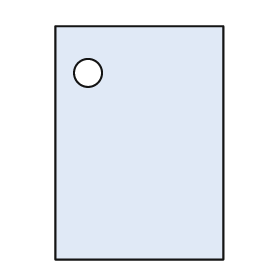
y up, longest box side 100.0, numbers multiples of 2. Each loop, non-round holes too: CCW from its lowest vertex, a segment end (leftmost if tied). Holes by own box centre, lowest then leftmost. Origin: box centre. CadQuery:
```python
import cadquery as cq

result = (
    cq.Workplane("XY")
    .moveTo(-36.0, -50.0)
    .lineTo(36.0, -50.0)
    .lineTo(36.0, 50.0)
    .lineTo(-36.0, 50.0)
    .close()
    .moveTo(-22.0, 30.0)
    .circle(6.0)
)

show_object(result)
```